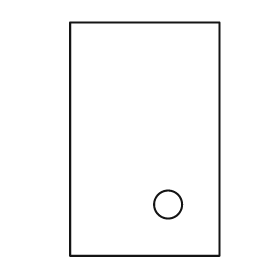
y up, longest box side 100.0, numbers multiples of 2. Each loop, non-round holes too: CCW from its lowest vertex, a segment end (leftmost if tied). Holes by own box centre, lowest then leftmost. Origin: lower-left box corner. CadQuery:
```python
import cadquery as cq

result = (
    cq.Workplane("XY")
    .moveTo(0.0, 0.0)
    .lineTo(64.0, 0.0)
    .lineTo(64.0, 100.0)
    .lineTo(0.0, 100.0)
    .close()
    .moveTo(42.0, 22.0)
    .circle(6.0)
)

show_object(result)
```